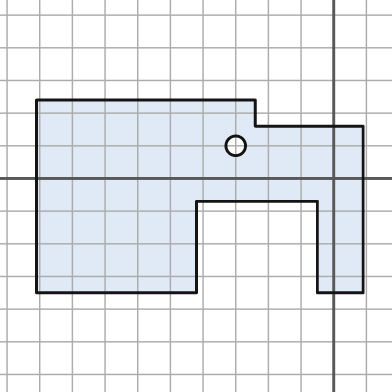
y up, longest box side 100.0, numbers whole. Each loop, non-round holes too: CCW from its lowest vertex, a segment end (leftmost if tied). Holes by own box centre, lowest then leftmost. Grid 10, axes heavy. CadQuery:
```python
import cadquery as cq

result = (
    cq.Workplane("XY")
    .moveTo(-91.0, -35.0)
    .lineTo(-42.0, -35.0)
    .lineTo(-42.0, -7.0)
    .lineTo(-5.0, -7.0)
    .lineTo(-5.0, -35.0)
    .lineTo(9.0, -35.0)
    .lineTo(9.0, 16.0)
    .lineTo(-24.0, 16.0)
    .lineTo(-24.0, 24.0)
    .lineTo(-91.0, 24.0)
    .close()
    .moveTo(-30.0, 10.0)
    .circle(3.0)
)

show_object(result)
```